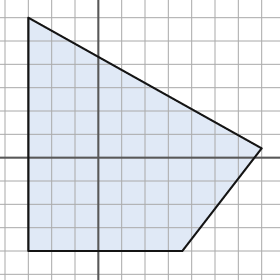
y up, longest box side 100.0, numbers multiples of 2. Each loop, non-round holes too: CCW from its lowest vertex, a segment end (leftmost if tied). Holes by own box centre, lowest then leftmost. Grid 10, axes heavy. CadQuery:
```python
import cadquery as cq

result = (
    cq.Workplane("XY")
    .moveTo(-30.0, -40.0)
    .lineTo(36.0, -40.0)
    .lineTo(70.0, 4.0)
    .lineTo(-30.0, 60.0)
    .close()
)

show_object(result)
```